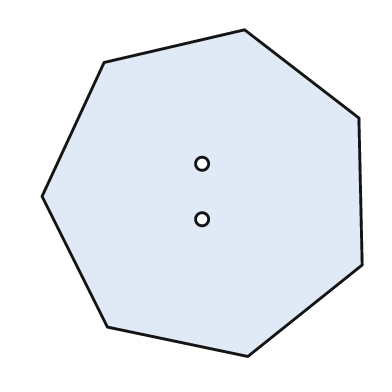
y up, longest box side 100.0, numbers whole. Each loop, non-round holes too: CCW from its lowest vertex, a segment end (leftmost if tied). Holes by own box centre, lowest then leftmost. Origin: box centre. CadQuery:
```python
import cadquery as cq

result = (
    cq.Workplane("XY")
    .moveTo(14.0, -50.0)
    .lineTo(49.0, -22.0)
    .lineTo(48.0, 23.0)
    .lineTo(13.0, 50.0)
    .lineTo(-30.0, 40.0)
    .lineTo(-49.0, -1.0)
    .lineTo(-29.0, -41.0)
    .close()
    .moveTo(0.0, -8.0)
    .circle(2.0)
    .moveTo(0.0, 9.0)
    .circle(2.0)
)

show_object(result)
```